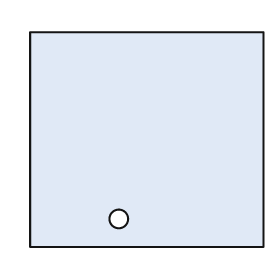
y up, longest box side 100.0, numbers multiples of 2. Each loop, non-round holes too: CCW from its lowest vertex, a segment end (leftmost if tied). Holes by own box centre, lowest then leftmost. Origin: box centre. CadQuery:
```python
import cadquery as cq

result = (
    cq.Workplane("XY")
    .moveTo(-50.0, -46.0)
    .lineTo(50.0, -46.0)
    .lineTo(50.0, 46.0)
    .lineTo(-50.0, 46.0)
    .close()
    .moveTo(-12.0, -34.0)
    .circle(4.0)
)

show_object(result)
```